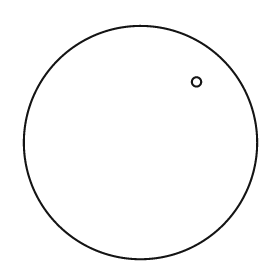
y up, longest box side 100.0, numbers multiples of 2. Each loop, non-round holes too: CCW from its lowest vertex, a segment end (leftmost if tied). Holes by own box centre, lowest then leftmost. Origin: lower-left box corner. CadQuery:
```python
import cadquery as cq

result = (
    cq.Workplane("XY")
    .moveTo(50.0, 50.0)
    .circle(50.0)
    .moveTo(74.0, 76.0)
    .circle(2.0)
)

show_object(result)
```